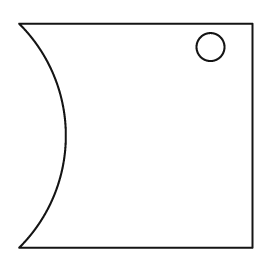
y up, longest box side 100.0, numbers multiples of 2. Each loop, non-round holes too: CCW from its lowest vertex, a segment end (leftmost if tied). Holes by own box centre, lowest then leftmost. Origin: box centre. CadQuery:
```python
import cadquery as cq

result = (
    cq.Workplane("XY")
    .moveTo(-50.0, -48.0)
    .lineTo(50.0, -48.0)
    .lineTo(50.0, 48.0)
    .lineTo(-50.0, 48.0)
    .threePointArc((-30.0, 0.0), (-50.0, -48.0))
    .close()
    .moveTo(32.0, 38.0)
    .circle(6.0)
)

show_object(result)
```